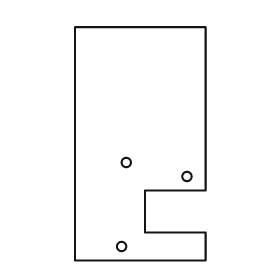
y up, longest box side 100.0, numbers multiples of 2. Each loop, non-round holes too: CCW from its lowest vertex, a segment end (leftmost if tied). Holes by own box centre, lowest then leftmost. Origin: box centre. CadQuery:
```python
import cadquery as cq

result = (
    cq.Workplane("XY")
    .moveTo(-28.0, -50.0)
    .lineTo(28.0, -50.0)
    .lineTo(28.0, -38.0)
    .lineTo(2.0, -38.0)
    .lineTo(2.0, -20.0)
    .lineTo(28.0, -20.0)
    .lineTo(28.0, 50.0)
    .lineTo(-28.0, 50.0)
    .close()
    .moveTo(-8.0, -44.0)
    .circle(2.0)
    .moveTo(20.0, -14.0)
    .circle(2.0)
    .moveTo(-6.0, -8.0)
    .circle(2.0)
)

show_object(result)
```